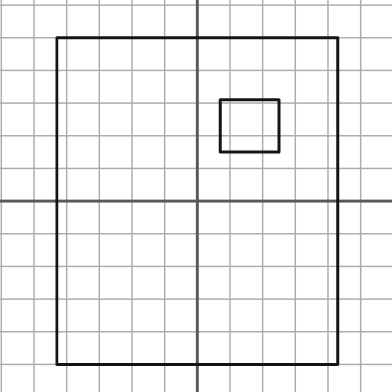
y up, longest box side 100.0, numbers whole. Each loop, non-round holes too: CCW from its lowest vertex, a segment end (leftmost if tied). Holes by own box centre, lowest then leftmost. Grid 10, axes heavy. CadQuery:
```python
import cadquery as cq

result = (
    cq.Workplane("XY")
    .moveTo(-43.0, -50.0)
    .lineTo(43.0, -50.0)
    .lineTo(43.0, 50.0)
    .lineTo(-43.0, 50.0)
    .close()
    .moveTo(7.0, 15.0)
    .lineTo(25.0, 15.0)
    .lineTo(25.0, 31.0)
    .lineTo(7.0, 31.0)
    .close()
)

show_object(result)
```